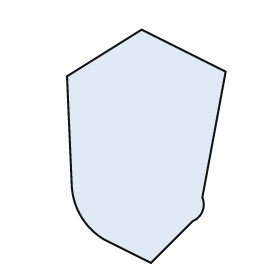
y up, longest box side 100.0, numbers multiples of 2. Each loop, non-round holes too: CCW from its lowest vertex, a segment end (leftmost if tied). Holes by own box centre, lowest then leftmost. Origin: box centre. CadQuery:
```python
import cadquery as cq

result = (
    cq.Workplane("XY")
    .moveTo(2.0, -50.0)
    .lineTo(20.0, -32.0)
    .threePointArc((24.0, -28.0), (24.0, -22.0))
    .lineTo(34.0, 32.0)
    .lineTo(-2.0, 50.0)
    .lineTo(-34.0, 30.0)
    .lineTo(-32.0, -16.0)
    .threePointArc((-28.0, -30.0), (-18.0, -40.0))
    .close()
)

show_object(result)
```